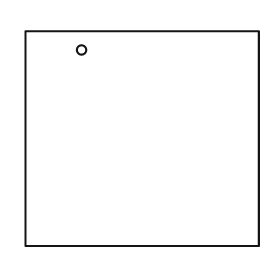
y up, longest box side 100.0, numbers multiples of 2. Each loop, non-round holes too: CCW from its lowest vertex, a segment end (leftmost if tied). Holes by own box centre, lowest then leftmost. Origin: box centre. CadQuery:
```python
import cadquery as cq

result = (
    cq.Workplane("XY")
    .moveTo(-50.0, -46.0)
    .lineTo(50.0, -46.0)
    .lineTo(50.0, 46.0)
    .lineTo(-50.0, 46.0)
    .close()
    .moveTo(-26.0, 38.0)
    .circle(2.0)
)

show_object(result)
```